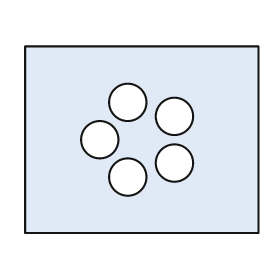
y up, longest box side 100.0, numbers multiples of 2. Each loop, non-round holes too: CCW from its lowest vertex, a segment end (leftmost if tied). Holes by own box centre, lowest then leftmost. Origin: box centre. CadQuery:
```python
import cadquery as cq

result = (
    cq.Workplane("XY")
    .moveTo(-50.0, -40.0)
    .lineTo(50.0, -40.0)
    .lineTo(50.0, 40.0)
    .lineTo(-50.0, 40.0)
    .close()
    .moveTo(-6.0, -16.0)
    .circle(8.0)
    .moveTo(14.0, -10.0)
    .circle(8.0)
    .moveTo(-18.0, 0.0)
    .circle(8.0)
    .moveTo(14.0, 10.0)
    .circle(8.0)
    .moveTo(-6.0, 16.0)
    .circle(8.0)
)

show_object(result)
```